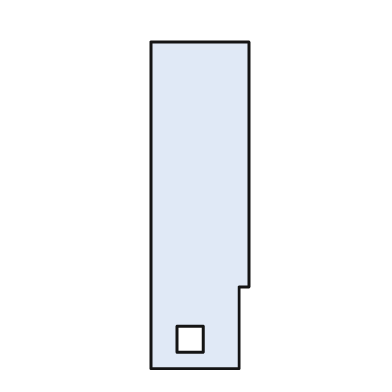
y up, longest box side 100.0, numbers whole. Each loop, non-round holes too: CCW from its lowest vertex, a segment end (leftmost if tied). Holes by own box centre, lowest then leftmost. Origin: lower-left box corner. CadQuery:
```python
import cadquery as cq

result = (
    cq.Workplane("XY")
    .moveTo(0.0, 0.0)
    .lineTo(27.0, 0.0)
    .lineTo(27.0, 25.0)
    .lineTo(30.0, 25.0)
    .lineTo(30.0, 100.0)
    .lineTo(0.0, 100.0)
    .close()
    .moveTo(8.0, 5.0)
    .lineTo(16.0, 5.0)
    .lineTo(16.0, 13.0)
    .lineTo(8.0, 13.0)
    .close()
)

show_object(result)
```